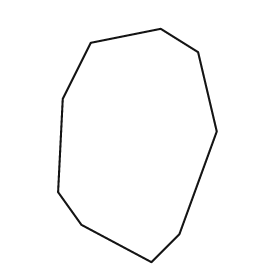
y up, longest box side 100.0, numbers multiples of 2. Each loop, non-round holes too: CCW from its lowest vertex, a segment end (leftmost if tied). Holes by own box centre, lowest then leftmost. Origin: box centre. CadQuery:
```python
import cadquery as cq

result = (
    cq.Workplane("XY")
    .moveTo(6.0, -50.0)
    .lineTo(18.0, -38.0)
    .lineTo(34.0, 6.0)
    .lineTo(26.0, 40.0)
    .lineTo(10.0, 50.0)
    .lineTo(-20.0, 44.0)
    .lineTo(-32.0, 20.0)
    .lineTo(-34.0, -20.0)
    .lineTo(-24.0, -34.0)
    .close()
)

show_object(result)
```